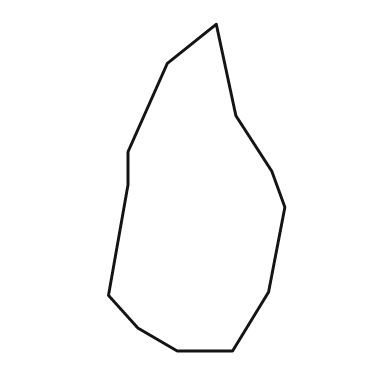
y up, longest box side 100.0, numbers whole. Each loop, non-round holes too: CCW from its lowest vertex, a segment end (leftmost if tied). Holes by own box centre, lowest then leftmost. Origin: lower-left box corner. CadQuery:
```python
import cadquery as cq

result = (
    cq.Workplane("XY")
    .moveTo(21.0, 0.0)
    .lineTo(38.0, 0.0)
    .lineTo(49.0, 18.0)
    .lineTo(54.0, 44.0)
    .lineTo(50.0, 55.0)
    .lineTo(39.0, 72.0)
    .lineTo(33.0, 100.0)
    .lineTo(18.0, 88.0)
    .lineTo(6.0, 61.0)
    .lineTo(6.0, 51.0)
    .lineTo(0.0, 17.0)
    .lineTo(9.0, 7.0)
    .close()
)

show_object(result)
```